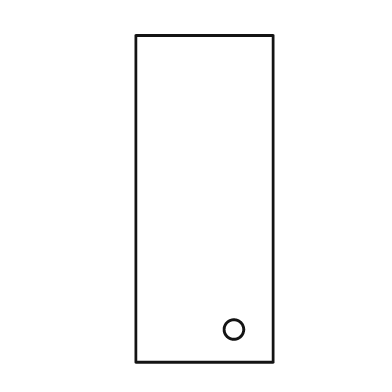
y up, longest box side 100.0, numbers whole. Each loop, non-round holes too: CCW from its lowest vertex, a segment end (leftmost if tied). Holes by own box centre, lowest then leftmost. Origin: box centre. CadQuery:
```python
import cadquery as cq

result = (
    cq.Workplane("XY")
    .moveTo(-21.0, -50.0)
    .lineTo(21.0, -50.0)
    .lineTo(21.0, 50.0)
    .lineTo(-21.0, 50.0)
    .close()
    .moveTo(9.0, -40.0)
    .circle(3.0)
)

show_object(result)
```